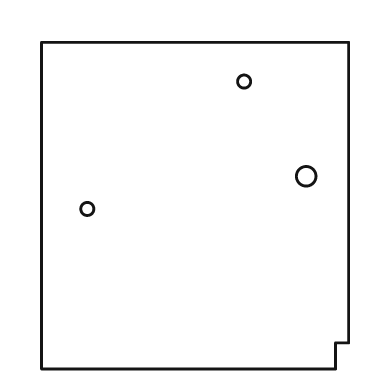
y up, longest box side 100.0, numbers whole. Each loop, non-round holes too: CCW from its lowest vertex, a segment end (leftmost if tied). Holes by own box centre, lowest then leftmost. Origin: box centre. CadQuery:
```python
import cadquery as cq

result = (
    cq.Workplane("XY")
    .moveTo(-47.0, -50.0)
    .lineTo(43.0, -50.0)
    .lineTo(43.0, -42.0)
    .lineTo(47.0, -42.0)
    .lineTo(47.0, 50.0)
    .lineTo(-47.0, 50.0)
    .close()
    .moveTo(-33.0, -1.0)
    .circle(2.0)
    .moveTo(34.0, 9.0)
    .circle(3.0)
    .moveTo(15.0, 38.0)
    .circle(2.0)
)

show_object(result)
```